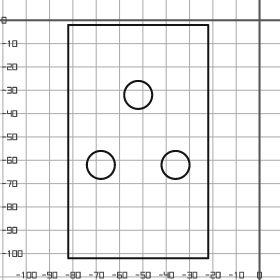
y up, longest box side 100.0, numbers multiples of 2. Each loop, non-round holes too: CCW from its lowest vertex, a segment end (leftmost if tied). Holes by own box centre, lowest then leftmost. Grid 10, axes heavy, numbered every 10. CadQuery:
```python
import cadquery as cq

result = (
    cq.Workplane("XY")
    .moveTo(-82.0, -102.0)
    .lineTo(-22.0, -102.0)
    .lineTo(-22.0, -2.0)
    .lineTo(-82.0, -2.0)
    .close()
    .moveTo(-68.0, -62.0)
    .circle(6.0)
    .moveTo(-36.0, -62.0)
    .circle(6.0)
    .moveTo(-52.0, -32.0)
    .circle(6.0)
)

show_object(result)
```